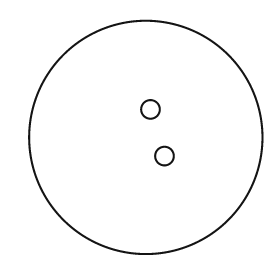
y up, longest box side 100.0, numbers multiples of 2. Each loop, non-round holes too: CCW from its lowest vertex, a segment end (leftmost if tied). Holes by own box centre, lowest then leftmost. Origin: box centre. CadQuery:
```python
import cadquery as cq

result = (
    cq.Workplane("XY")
    .moveTo(0.0, 0.0)
    .circle(50.0)
    .moveTo(8.0, -8.0)
    .circle(4.0)
    .moveTo(2.0, 12.0)
    .circle(4.0)
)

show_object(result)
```